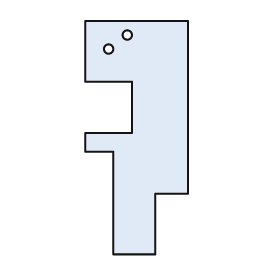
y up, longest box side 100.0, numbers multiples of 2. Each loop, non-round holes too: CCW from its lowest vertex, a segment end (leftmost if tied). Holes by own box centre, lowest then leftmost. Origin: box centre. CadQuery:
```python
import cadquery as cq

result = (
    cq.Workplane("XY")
    .moveTo(-10.0, -50.0)
    .lineTo(8.0, -50.0)
    .lineTo(8.0, -24.0)
    .lineTo(22.0, -24.0)
    .lineTo(22.0, 50.0)
    .lineTo(-22.0, 50.0)
    .lineTo(-22.0, 24.0)
    .lineTo(-2.0, 24.0)
    .lineTo(-2.0, 2.0)
    .lineTo(-22.0, 2.0)
    .lineTo(-22.0, -6.0)
    .lineTo(-10.0, -6.0)
    .close()
    .moveTo(-12.0, 38.0)
    .circle(2.0)
    .moveTo(-4.0, 44.0)
    .circle(2.0)
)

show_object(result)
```